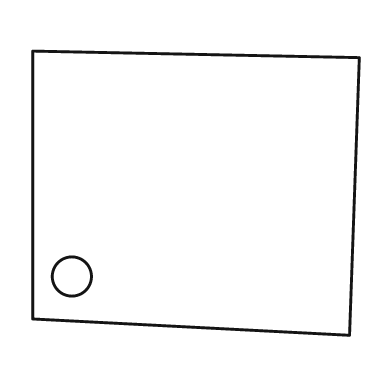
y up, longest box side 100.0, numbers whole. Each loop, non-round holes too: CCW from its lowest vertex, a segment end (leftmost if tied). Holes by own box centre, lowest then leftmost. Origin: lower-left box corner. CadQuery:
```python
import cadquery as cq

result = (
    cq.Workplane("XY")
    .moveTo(97.0, 0.0)
    .lineTo(100.0, 85.0)
    .lineTo(0.0, 87.0)
    .lineTo(0.0, 5.0)
    .close()
    .moveTo(12.0, 18.0)
    .circle(6.0)
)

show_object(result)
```